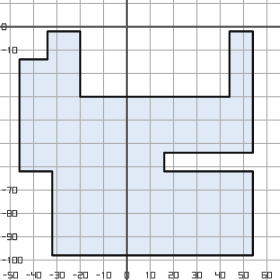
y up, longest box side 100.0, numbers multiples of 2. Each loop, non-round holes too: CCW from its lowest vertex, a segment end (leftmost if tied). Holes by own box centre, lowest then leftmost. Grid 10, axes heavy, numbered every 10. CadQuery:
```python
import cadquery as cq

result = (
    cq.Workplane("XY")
    .moveTo(-32.0, -98.0)
    .lineTo(54.0, -98.0)
    .lineTo(54.0, -62.0)
    .lineTo(16.0, -62.0)
    .lineTo(16.0, -54.0)
    .lineTo(54.0, -54.0)
    .lineTo(54.0, -2.0)
    .lineTo(44.0, -2.0)
    .lineTo(44.0, -30.0)
    .lineTo(-20.0, -30.0)
    .lineTo(-20.0, -2.0)
    .lineTo(-34.0, -2.0)
    .lineTo(-34.0, -14.0)
    .lineTo(-46.0, -14.0)
    .lineTo(-46.0, -62.0)
    .lineTo(-32.0, -62.0)
    .close()
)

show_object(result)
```